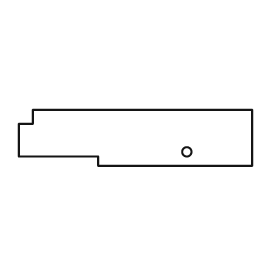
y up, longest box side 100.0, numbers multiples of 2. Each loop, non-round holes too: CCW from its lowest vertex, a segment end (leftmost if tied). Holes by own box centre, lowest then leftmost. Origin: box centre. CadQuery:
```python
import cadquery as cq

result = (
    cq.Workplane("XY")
    .moveTo(-16.0, -12.0)
    .lineTo(50.0, -12.0)
    .lineTo(50.0, 12.0)
    .lineTo(-44.0, 12.0)
    .lineTo(-44.0, 6.0)
    .lineTo(-50.0, 6.0)
    .lineTo(-50.0, -8.0)
    .lineTo(-16.0, -8.0)
    .close()
    .moveTo(22.0, -6.0)
    .circle(2.0)
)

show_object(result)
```